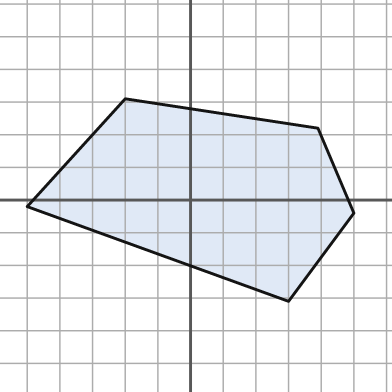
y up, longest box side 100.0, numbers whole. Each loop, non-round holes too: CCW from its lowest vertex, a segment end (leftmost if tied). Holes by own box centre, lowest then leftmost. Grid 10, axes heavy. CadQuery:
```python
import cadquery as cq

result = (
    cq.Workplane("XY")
    .moveTo(30.0, -31.0)
    .lineTo(50.0, -4.0)
    .lineTo(39.0, 22.0)
    .lineTo(-20.0, 31.0)
    .lineTo(-50.0, -2.0)
    .close()
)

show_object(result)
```